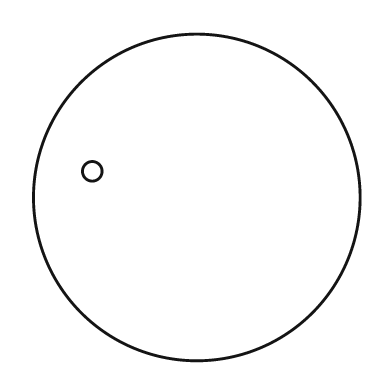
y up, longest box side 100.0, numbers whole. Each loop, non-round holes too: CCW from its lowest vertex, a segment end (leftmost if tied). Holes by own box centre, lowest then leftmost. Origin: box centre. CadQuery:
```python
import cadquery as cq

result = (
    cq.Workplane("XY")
    .moveTo(0.0, 0.0)
    .circle(50.0)
    .moveTo(-32.0, 8.0)
    .circle(3.0)
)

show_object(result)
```